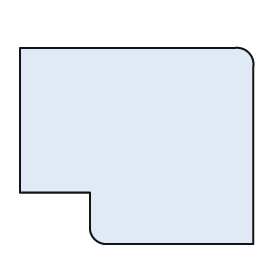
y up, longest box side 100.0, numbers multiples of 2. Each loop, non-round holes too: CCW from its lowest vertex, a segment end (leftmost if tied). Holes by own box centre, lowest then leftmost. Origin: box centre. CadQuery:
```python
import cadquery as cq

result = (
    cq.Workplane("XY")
    .moveTo(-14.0, -42.0)
    .lineTo(50.0, -42.0)
    .lineTo(50.0, 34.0)
    .threePointArc((48.0, 40.0), (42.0, 42.0))
    .lineTo(-50.0, 42.0)
    .lineTo(-50.0, -20.0)
    .lineTo(-20.0, -20.0)
    .lineTo(-20.0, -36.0)
    .threePointArc((-18.0, -40.0), (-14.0, -42.0))
    .close()
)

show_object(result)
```